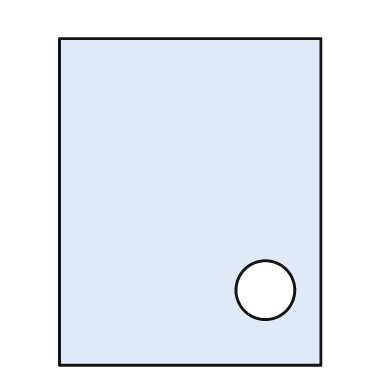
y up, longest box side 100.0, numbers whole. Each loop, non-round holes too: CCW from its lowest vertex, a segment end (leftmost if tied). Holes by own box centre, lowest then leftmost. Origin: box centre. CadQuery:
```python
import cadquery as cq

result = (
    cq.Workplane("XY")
    .moveTo(-40.0, -50.0)
    .lineTo(40.0, -50.0)
    .lineTo(40.0, 50.0)
    .lineTo(-40.0, 50.0)
    .close()
    .moveTo(23.0, -27.0)
    .circle(9.0)
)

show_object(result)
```